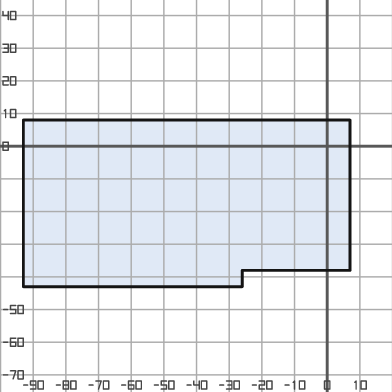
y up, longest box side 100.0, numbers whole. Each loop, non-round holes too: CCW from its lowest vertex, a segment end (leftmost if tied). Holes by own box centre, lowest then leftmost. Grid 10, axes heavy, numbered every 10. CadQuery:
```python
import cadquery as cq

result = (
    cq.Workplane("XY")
    .moveTo(-93.0, -43.0)
    .lineTo(-26.0, -43.0)
    .lineTo(-26.0, -38.0)
    .lineTo(7.0, -38.0)
    .lineTo(7.0, 8.0)
    .lineTo(-93.0, 8.0)
    .close()
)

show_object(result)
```